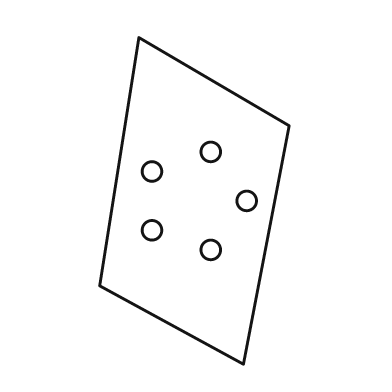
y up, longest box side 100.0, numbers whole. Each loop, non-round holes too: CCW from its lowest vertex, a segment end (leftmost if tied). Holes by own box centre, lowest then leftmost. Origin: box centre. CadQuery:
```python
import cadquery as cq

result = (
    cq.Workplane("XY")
    .moveTo(15.0, -50.0)
    .lineTo(29.0, 23.0)
    .lineTo(-17.0, 50.0)
    .lineTo(-29.0, -26.0)
    .close()
    .moveTo(5.0, -15.0)
    .circle(3.0)
    .moveTo(-13.0, -9.0)
    .circle(3.0)
    .moveTo(16.0, 0.0)
    .circle(3.0)
    .moveTo(-13.0, 9.0)
    .circle(3.0)
    .moveTo(5.0, 15.0)
    .circle(3.0)
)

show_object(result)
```